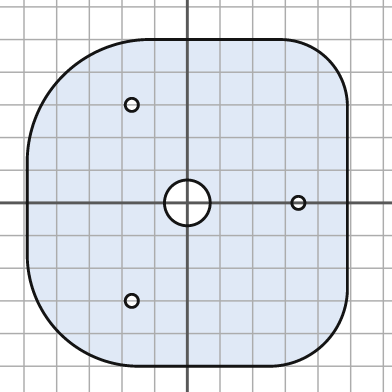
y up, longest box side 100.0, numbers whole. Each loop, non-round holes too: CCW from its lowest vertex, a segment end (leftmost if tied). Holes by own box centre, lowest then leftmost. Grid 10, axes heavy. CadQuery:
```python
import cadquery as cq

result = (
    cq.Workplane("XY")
    .moveTo(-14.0, -50.0)
    .lineTo(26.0, -50.0)
    .threePointArc((42.0, -43.0), (49.0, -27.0))
    .lineTo(49.0, 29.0)
    .threePointArc((43.0, 44.0), (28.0, 50.0))
    .lineTo(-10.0, 50.0)
    .threePointArc((-38.0, 39.0), (-49.0, 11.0))
    .lineTo(-49.0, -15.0)
    .threePointArc((-39.0, -40.0), (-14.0, -50.0))
    .close()
    .moveTo(-17.0, -30.0)
    .circle(2.0)
    .moveTo(0.0, 0.0)
    .circle(7.0)
    .moveTo(34.0, 0.0)
    .circle(2.0)
    .moveTo(-17.0, 30.0)
    .circle(2.0)
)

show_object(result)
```